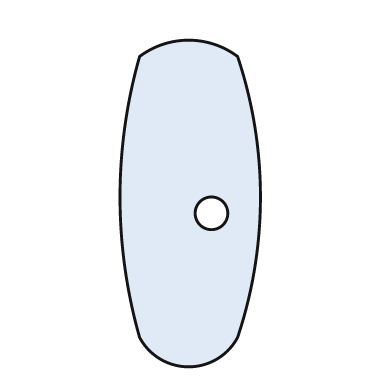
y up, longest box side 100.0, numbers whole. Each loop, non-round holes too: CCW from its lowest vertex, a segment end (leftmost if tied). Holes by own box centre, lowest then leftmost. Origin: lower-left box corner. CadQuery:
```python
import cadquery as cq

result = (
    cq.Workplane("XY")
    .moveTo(6.0, 9.0)
    .threePointArc((21.0, 0.0), (36.0, 9.0))
    .threePointArc((43.0, 52.0), (36.0, 95.0))
    .threePointArc((21.0, 100.0), (6.0, 95.0))
    .threePointArc((0.0, 52.0), (6.0, 9.0))
    .close()
    .moveTo(28.0, 47.0)
    .circle(5.0)
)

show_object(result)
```